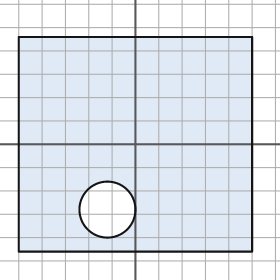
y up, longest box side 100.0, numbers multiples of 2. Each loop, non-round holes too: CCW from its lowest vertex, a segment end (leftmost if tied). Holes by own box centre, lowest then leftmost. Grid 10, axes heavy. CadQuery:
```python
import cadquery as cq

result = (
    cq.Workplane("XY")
    .moveTo(-50.0, -46.0)
    .lineTo(50.0, -46.0)
    .lineTo(50.0, 46.0)
    .lineTo(-50.0, 46.0)
    .close()
    .moveTo(-12.0, -28.0)
    .circle(12.0)
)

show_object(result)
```